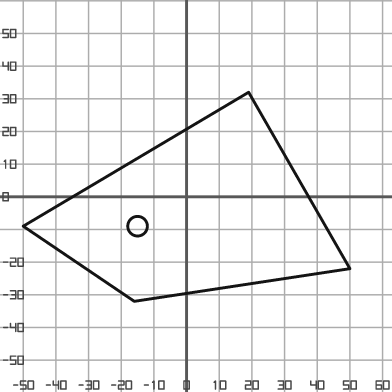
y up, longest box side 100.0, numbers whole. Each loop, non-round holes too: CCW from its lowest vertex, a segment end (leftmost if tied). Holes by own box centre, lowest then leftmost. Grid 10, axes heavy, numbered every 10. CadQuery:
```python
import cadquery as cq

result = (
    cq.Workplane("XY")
    .moveTo(-16.0, -32.0)
    .lineTo(50.0, -22.0)
    .lineTo(19.0, 32.0)
    .lineTo(-50.0, -9.0)
    .close()
    .moveTo(-15.0, -9.0)
    .circle(3.0)
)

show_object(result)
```